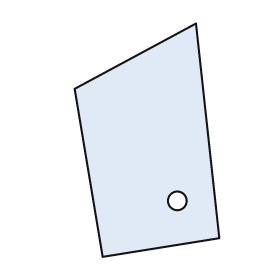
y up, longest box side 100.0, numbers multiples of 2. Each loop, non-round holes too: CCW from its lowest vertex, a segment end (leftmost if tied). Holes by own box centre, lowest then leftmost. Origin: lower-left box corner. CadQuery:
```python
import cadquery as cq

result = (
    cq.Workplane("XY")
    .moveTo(12.0, 0.0)
    .lineTo(62.0, 8.0)
    .lineTo(52.0, 100.0)
    .lineTo(0.0, 72.0)
    .close()
    .moveTo(44.0, 24.0)
    .circle(4.0)
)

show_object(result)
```